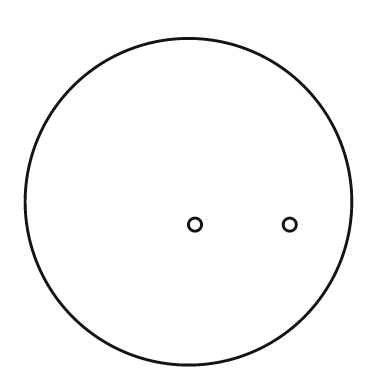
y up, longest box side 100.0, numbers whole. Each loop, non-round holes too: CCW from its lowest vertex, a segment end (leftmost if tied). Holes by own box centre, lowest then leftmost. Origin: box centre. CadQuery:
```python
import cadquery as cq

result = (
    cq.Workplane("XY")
    .moveTo(0.0, 0.0)
    .circle(50.0)
    .moveTo(2.0, -7.0)
    .circle(2.0)
    .moveTo(31.0, -7.0)
    .circle(2.0)
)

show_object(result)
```